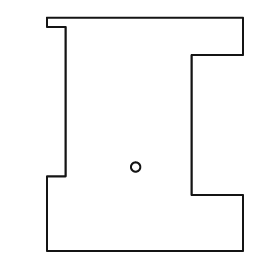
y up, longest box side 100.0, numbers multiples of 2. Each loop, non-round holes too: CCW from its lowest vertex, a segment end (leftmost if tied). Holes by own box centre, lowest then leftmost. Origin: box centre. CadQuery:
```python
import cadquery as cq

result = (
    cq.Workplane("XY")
    .moveTo(-42.0, -50.0)
    .lineTo(42.0, -50.0)
    .lineTo(42.0, -26.0)
    .lineTo(20.0, -26.0)
    .lineTo(20.0, 34.0)
    .lineTo(42.0, 34.0)
    .lineTo(42.0, 50.0)
    .lineTo(-42.0, 50.0)
    .lineTo(-42.0, 46.0)
    .lineTo(-34.0, 46.0)
    .lineTo(-34.0, -18.0)
    .lineTo(-42.0, -18.0)
    .close()
    .moveTo(-4.0, -14.0)
    .circle(2.0)
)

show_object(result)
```